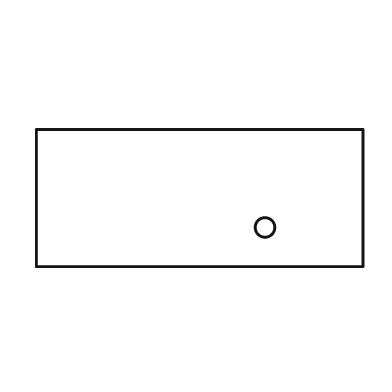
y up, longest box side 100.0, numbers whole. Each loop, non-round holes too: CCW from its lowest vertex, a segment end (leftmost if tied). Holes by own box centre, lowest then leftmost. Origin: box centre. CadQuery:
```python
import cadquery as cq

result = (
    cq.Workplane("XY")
    .moveTo(-50.0, -21.0)
    .lineTo(50.0, -21.0)
    .lineTo(50.0, 21.0)
    .lineTo(-50.0, 21.0)
    .close()
    .moveTo(20.0, -9.0)
    .circle(3.0)
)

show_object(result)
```